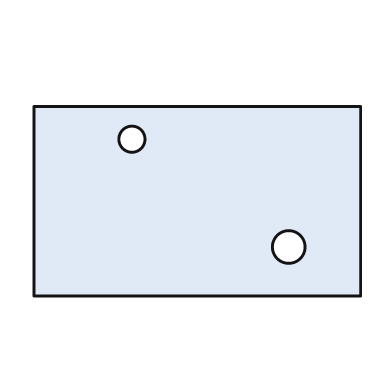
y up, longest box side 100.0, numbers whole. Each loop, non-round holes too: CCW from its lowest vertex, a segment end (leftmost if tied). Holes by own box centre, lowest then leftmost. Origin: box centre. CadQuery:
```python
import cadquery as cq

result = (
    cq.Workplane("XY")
    .moveTo(-50.0, -29.0)
    .lineTo(50.0, -29.0)
    .lineTo(50.0, 29.0)
    .lineTo(-50.0, 29.0)
    .close()
    .moveTo(28.0, -14.0)
    .circle(5.0)
    .moveTo(-20.0, 19.0)
    .circle(4.0)
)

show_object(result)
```